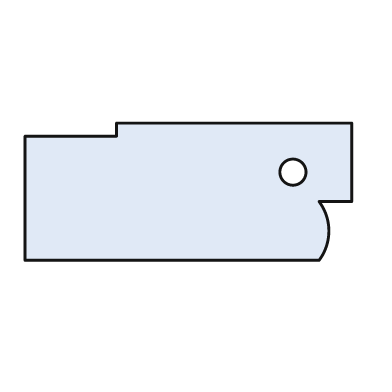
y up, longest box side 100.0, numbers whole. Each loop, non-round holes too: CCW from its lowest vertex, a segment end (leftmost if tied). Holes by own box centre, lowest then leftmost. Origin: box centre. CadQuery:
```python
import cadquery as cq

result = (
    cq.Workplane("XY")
    .moveTo(-50.0, -21.0)
    .lineTo(40.0, -21.0)
    .threePointArc((43.0, -12.0), (40.0, -3.0))
    .lineTo(50.0, -3.0)
    .lineTo(50.0, 21.0)
    .lineTo(-22.0, 21.0)
    .lineTo(-22.0, 17.0)
    .lineTo(-50.0, 17.0)
    .close()
    .moveTo(32.0, 6.0)
    .circle(4.0)
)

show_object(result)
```